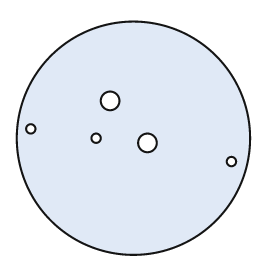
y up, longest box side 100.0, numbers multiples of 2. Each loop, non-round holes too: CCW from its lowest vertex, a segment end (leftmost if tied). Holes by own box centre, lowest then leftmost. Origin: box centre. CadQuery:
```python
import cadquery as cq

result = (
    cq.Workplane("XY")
    .moveTo(0.0, 0.0)
    .circle(50.0)
    .moveTo(42.0, -10.0)
    .circle(2.0)
    .moveTo(6.0, -2.0)
    .circle(4.0)
    .moveTo(-16.0, 0.0)
    .circle(2.0)
    .moveTo(-44.0, 4.0)
    .circle(2.0)
    .moveTo(-10.0, 16.0)
    .circle(4.0)
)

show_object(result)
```